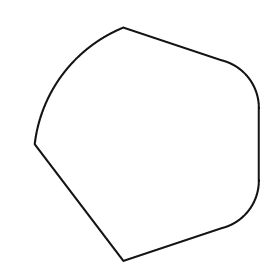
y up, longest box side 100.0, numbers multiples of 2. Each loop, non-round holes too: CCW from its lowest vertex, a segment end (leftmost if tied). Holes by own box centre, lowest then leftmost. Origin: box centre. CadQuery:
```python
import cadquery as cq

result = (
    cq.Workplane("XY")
    .moveTo(-10.0, -50.0)
    .lineTo(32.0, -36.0)
    .threePointArc((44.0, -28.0), (48.0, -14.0))
    .lineTo(48.0, 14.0)
    .threePointArc((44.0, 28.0), (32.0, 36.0))
    .lineTo(-10.0, 50.0)
    .threePointArc((-36.0, 30.0), (-48.0, 0.0))
    .close()
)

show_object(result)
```